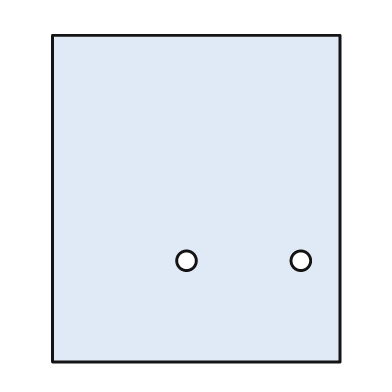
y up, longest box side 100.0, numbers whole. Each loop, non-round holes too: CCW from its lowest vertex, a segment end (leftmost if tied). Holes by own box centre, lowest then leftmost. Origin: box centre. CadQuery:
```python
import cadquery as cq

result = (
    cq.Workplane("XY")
    .moveTo(-44.0, -50.0)
    .lineTo(44.0, -50.0)
    .lineTo(44.0, 50.0)
    .lineTo(-44.0, 50.0)
    .close()
    .moveTo(-3.0, -19.0)
    .circle(3.0)
    .moveTo(32.0, -19.0)
    .circle(3.0)
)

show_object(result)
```